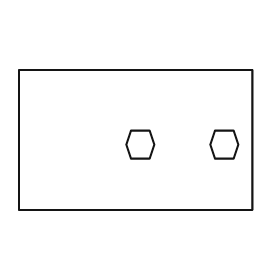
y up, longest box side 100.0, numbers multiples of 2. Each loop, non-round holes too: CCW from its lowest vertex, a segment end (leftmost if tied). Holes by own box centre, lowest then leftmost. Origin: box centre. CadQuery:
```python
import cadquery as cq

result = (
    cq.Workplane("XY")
    .moveTo(-50.0, -30.0)
    .lineTo(50.0, -30.0)
    .lineTo(50.0, 30.0)
    .lineTo(-50.0, 30.0)
    .close()
    .moveTo(-2.0, -8.0)
    .lineTo(6.0, -8.0)
    .lineTo(8.0, -2.0)
    .lineTo(6.0, 4.0)
    .lineTo(-2.0, 4.0)
    .lineTo(-4.0, -2.0)
    .close()
    .moveTo(34.0, -8.0)
    .lineTo(42.0, -8.0)
    .lineTo(44.0, -2.0)
    .lineTo(42.0, 4.0)
    .lineTo(34.0, 4.0)
    .lineTo(32.0, -2.0)
    .close()
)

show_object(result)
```